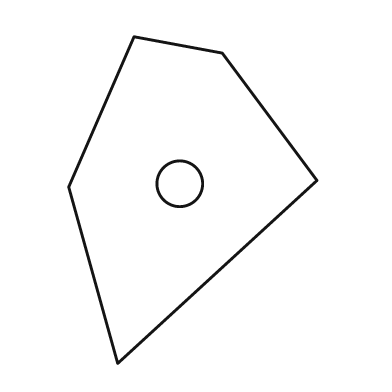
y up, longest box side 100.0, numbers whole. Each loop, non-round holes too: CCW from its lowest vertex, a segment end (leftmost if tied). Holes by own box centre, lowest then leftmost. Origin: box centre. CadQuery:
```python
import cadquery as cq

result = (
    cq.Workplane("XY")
    .moveTo(-23.0, -50.0)
    .lineTo(38.0, 6.0)
    .lineTo(9.0, 45.0)
    .lineTo(-18.0, 50.0)
    .lineTo(-38.0, 4.0)
    .close()
    .moveTo(-4.0, 5.0)
    .circle(7.0)
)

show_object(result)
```